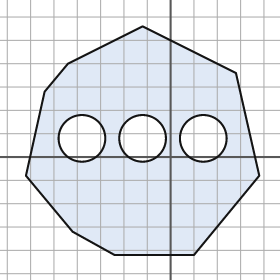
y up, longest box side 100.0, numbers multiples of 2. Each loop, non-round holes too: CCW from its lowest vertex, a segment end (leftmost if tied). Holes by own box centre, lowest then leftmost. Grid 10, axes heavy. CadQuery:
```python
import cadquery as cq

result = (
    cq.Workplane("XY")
    .moveTo(-24.0, -42.0)
    .lineTo(10.0, -42.0)
    .lineTo(38.0, -8.0)
    .lineTo(28.0, 36.0)
    .lineTo(-12.0, 56.0)
    .lineTo(-44.0, 40.0)
    .lineTo(-54.0, 28.0)
    .lineTo(-62.0, -8.0)
    .lineTo(-42.0, -32.0)
    .close()
    .moveTo(-38.0, 8.0)
    .circle(10.0)
    .moveTo(-12.0, 8.0)
    .circle(10.0)
    .moveTo(14.0, 8.0)
    .circle(10.0)
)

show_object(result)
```